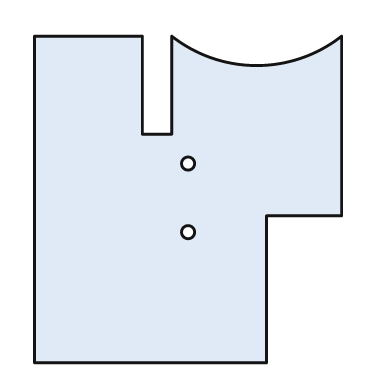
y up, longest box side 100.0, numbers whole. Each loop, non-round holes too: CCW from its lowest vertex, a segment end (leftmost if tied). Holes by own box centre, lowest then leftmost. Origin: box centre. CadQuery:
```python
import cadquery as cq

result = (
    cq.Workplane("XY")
    .moveTo(-47.0, -50.0)
    .lineTo(24.0, -50.0)
    .lineTo(24.0, -5.0)
    .lineTo(47.0, -5.0)
    .lineTo(47.0, 50.0)
    .threePointArc((21.0, 41.0), (-5.0, 50.0))
    .lineTo(-5.0, 20.0)
    .lineTo(-14.0, 20.0)
    .lineTo(-14.0, 50.0)
    .lineTo(-47.0, 50.0)
    .close()
    .moveTo(0.0, -10.0)
    .circle(2.0)
    .moveTo(0.0, 11.0)
    .circle(2.0)
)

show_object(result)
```